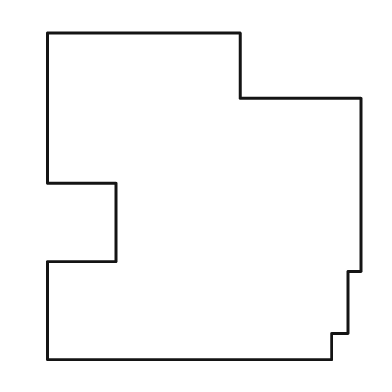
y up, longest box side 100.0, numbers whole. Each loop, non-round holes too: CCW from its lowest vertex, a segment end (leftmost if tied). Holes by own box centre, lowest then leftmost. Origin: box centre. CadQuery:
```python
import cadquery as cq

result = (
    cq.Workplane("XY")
    .moveTo(-48.0, -50.0)
    .lineTo(39.0, -50.0)
    .lineTo(39.0, -42.0)
    .lineTo(44.0, -42.0)
    .lineTo(44.0, -23.0)
    .lineTo(48.0, -23.0)
    .lineTo(48.0, 30.0)
    .lineTo(11.0, 30.0)
    .lineTo(11.0, 50.0)
    .lineTo(-48.0, 50.0)
    .lineTo(-48.0, 4.0)
    .lineTo(-27.0, 4.0)
    .lineTo(-27.0, -20.0)
    .lineTo(-48.0, -20.0)
    .close()
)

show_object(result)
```